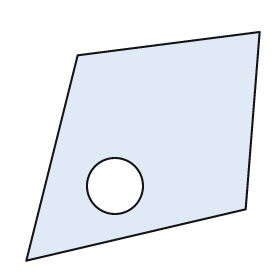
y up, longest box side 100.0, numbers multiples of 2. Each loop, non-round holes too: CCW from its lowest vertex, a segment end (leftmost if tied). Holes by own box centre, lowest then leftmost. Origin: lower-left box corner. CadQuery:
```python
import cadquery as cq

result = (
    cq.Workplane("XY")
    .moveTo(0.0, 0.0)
    .lineTo(94.0, 22.0)
    .lineTo(100.0, 98.0)
    .lineTo(22.0, 88.0)
    .close()
    .moveTo(38.0, 32.0)
    .circle(12.0)
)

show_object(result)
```